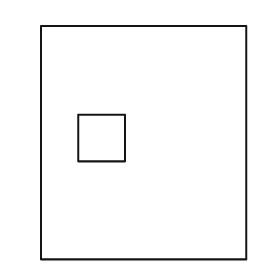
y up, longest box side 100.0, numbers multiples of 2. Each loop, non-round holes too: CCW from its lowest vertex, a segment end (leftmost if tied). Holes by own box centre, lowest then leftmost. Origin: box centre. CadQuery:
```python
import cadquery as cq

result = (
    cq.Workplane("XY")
    .moveTo(-44.0, -50.0)
    .lineTo(44.0, -50.0)
    .lineTo(44.0, 50.0)
    .lineTo(-44.0, 50.0)
    .close()
    .moveTo(-28.0, -8.0)
    .lineTo(-8.0, -8.0)
    .lineTo(-8.0, 12.0)
    .lineTo(-28.0, 12.0)
    .close()
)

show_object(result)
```